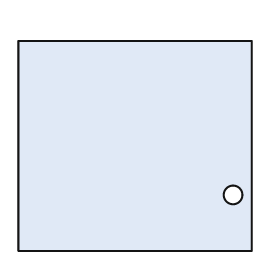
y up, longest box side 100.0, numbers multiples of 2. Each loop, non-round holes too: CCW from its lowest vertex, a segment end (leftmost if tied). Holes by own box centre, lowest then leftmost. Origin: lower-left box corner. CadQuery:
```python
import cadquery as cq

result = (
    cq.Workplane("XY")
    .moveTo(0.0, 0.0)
    .lineTo(100.0, 0.0)
    .lineTo(100.0, 90.0)
    .lineTo(0.0, 90.0)
    .close()
    .moveTo(92.0, 24.0)
    .circle(4.0)
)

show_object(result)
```